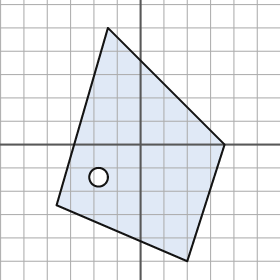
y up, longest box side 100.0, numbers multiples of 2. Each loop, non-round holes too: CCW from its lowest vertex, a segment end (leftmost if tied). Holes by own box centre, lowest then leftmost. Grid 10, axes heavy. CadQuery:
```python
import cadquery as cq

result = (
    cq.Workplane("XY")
    .moveTo(20.0, -50.0)
    .lineTo(36.0, 0.0)
    .lineTo(-14.0, 50.0)
    .lineTo(-36.0, -26.0)
    .close()
    .moveTo(-18.0, -14.0)
    .circle(4.0)
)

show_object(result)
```